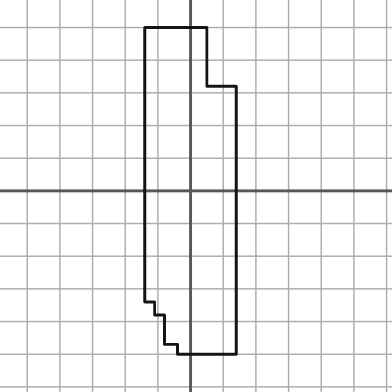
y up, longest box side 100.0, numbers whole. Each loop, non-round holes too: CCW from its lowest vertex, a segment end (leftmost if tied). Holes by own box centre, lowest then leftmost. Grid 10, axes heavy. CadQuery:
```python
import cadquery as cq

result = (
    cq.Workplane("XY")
    .moveTo(-4.0, -50.0)
    .lineTo(14.0, -50.0)
    .lineTo(14.0, 32.0)
    .lineTo(5.0, 32.0)
    .lineTo(5.0, 50.0)
    .lineTo(-14.0, 50.0)
    .lineTo(-14.0, -34.0)
    .lineTo(-11.0, -34.0)
    .lineTo(-11.0, -38.0)
    .lineTo(-8.0, -38.0)
    .lineTo(-8.0, -47.0)
    .lineTo(-4.0, -47.0)
    .close()
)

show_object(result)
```